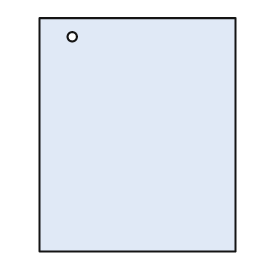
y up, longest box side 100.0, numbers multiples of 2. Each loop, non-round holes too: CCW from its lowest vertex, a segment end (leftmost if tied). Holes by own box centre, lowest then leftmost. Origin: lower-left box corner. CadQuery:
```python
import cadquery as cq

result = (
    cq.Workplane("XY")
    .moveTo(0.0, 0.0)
    .lineTo(84.0, 0.0)
    .lineTo(84.0, 100.0)
    .lineTo(0.0, 100.0)
    .close()
    .moveTo(14.0, 92.0)
    .circle(2.0)
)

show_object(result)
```